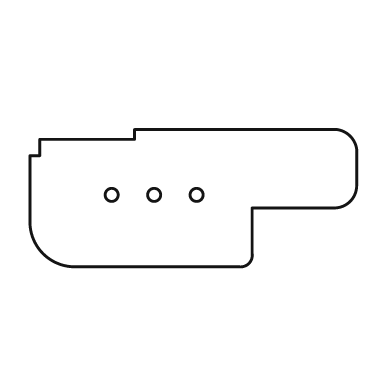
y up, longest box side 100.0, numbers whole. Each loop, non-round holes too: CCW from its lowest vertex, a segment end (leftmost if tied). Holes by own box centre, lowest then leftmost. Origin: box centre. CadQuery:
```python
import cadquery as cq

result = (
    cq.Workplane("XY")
    .moveTo(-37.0, -21.0)
    .lineTo(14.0, -21.0)
    .threePointArc((17.0, -20.0), (18.0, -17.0))
    .lineTo(18.0, -3.0)
    .lineTo(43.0, -3.0)
    .threePointArc((48.0, -1.0), (50.0, 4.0))
    .lineTo(50.0, 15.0)
    .threePointArc((48.0, 19.0), (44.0, 21.0))
    .lineTo(-18.0, 21.0)
    .lineTo(-18.0, 18.0)
    .lineTo(-47.0, 18.0)
    .lineTo(-47.0, 13.0)
    .lineTo(-50.0, 13.0)
    .lineTo(-50.0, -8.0)
    .threePointArc((-46.0, -17.0), (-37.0, -21.0))
    .close()
    .moveTo(-25.0, 1.0)
    .circle(2.0)
    .moveTo(-12.0, 1.0)
    .circle(2.0)
    .moveTo(1.0, 1.0)
    .circle(2.0)
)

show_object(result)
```